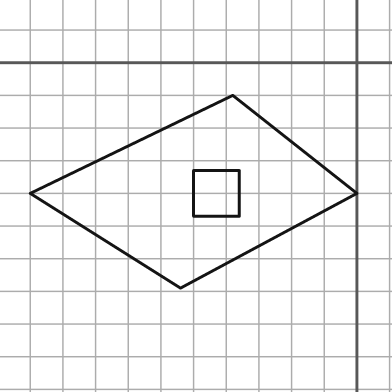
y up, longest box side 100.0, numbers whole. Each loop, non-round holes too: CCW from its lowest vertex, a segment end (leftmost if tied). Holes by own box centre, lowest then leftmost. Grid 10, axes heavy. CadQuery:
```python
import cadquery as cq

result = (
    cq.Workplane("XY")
    .moveTo(-54.0, -69.0)
    .lineTo(0.0, -40.0)
    .lineTo(-38.0, -10.0)
    .lineTo(-100.0, -40.0)
    .close()
    .moveTo(-50.0, -47.0)
    .lineTo(-36.0, -47.0)
    .lineTo(-36.0, -33.0)
    .lineTo(-50.0, -33.0)
    .close()
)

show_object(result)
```